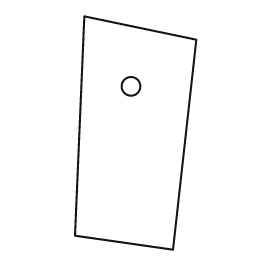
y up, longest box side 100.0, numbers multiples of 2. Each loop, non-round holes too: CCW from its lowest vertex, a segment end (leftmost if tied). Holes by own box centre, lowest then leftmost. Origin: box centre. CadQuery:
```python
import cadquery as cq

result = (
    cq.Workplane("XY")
    .moveTo(16.0, -50.0)
    .lineTo(26.0, 40.0)
    .lineTo(-22.0, 50.0)
    .lineTo(-26.0, -44.0)
    .close()
    .moveTo(-2.0, 20.0)
    .circle(4.0)
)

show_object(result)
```